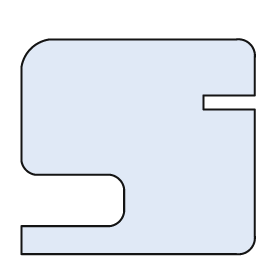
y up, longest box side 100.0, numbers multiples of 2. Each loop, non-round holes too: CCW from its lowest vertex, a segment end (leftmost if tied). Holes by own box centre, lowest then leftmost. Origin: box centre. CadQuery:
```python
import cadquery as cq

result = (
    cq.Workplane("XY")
    .moveTo(-50.0, -46.0)
    .lineTo(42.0, -46.0)
    .threePointArc((48.0, -44.0), (50.0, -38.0))
    .lineTo(50.0, 16.0)
    .lineTo(28.0, 16.0)
    .lineTo(28.0, 22.0)
    .lineTo(50.0, 22.0)
    .lineTo(50.0, 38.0)
    .threePointArc((48.0, 44.0), (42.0, 46.0))
    .lineTo(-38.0, 46.0)
    .threePointArc((-46.0, 42.0), (-50.0, 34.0))
    .lineTo(-50.0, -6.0)
    .threePointArc((-48.0, -10.0), (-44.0, -12.0))
    .lineTo(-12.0, -12.0)
    .threePointArc((-8.0, -14.0), (-6.0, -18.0))
    .lineTo(-6.0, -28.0)
    .threePointArc((-8.0, -32.0), (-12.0, -34.0))
    .lineTo(-50.0, -34.0)
    .close()
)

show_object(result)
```